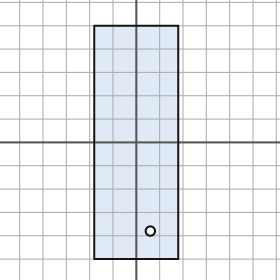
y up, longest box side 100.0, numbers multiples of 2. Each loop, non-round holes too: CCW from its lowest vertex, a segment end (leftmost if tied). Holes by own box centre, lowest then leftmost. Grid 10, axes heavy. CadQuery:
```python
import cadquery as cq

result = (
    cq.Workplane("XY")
    .moveTo(-18.0, -50.0)
    .lineTo(18.0, -50.0)
    .lineTo(18.0, 50.0)
    .lineTo(-18.0, 50.0)
    .close()
    .moveTo(6.0, -38.0)
    .circle(2.0)
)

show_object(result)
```